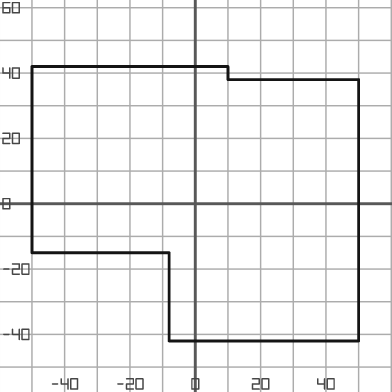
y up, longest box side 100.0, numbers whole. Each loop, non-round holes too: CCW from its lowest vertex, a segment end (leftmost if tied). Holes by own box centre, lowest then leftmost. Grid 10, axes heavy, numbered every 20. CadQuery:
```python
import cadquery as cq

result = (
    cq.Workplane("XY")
    .moveTo(-8.0, -42.0)
    .lineTo(50.0, -42.0)
    .lineTo(50.0, 38.0)
    .lineTo(10.0, 38.0)
    .lineTo(10.0, 42.0)
    .lineTo(-50.0, 42.0)
    .lineTo(-50.0, -15.0)
    .lineTo(-8.0, -15.0)
    .close()
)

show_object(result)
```